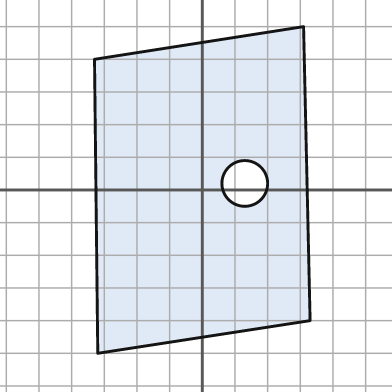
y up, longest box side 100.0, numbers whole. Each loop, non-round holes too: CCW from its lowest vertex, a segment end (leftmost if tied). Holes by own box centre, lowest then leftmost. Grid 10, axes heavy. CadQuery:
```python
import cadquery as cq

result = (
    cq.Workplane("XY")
    .moveTo(-32.0, -50.0)
    .lineTo(33.0, -40.0)
    .lineTo(31.0, 50.0)
    .lineTo(-33.0, 40.0)
    .close()
    .moveTo(13.0, 2.0)
    .circle(7.0)
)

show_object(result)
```